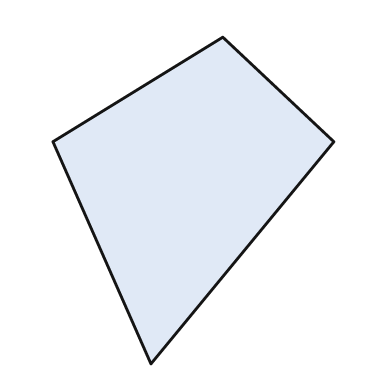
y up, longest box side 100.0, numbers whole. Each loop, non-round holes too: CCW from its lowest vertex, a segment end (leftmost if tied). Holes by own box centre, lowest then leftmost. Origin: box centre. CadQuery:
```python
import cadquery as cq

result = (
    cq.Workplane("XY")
    .moveTo(-13.0, -50.0)
    .lineTo(43.0, 18.0)
    .lineTo(9.0, 50.0)
    .lineTo(-43.0, 18.0)
    .close()
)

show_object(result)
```